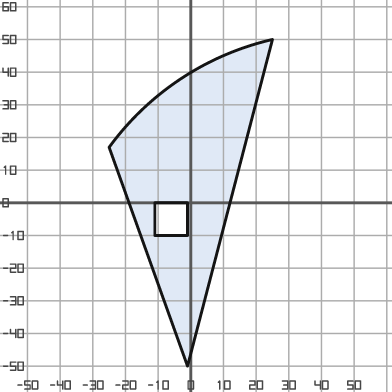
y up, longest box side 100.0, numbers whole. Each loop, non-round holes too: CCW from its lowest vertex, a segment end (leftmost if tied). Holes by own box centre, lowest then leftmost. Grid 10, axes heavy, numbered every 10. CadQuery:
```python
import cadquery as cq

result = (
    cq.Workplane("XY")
    .moveTo(-1.0, -50.0)
    .lineTo(25.0, 50.0)
    .threePointArc((-3.0, 38.0), (-25.0, 17.0))
    .close()
    .moveTo(-11.0, -10.0)
    .lineTo(-1.0, -10.0)
    .lineTo(-1.0, 0.0)
    .lineTo(-11.0, 0.0)
    .close()
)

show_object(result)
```